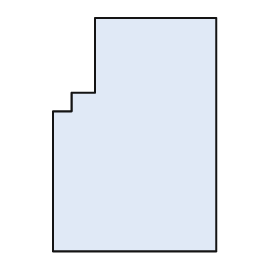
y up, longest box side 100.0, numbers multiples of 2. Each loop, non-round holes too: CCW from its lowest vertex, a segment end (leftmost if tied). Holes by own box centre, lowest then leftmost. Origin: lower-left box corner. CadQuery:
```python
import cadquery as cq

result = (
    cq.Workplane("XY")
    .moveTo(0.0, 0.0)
    .lineTo(70.0, 0.0)
    .lineTo(70.0, 100.0)
    .lineTo(18.0, 100.0)
    .lineTo(18.0, 68.0)
    .lineTo(8.0, 68.0)
    .lineTo(8.0, 60.0)
    .lineTo(0.0, 60.0)
    .close()
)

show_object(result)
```